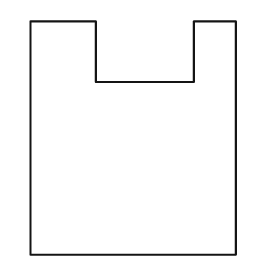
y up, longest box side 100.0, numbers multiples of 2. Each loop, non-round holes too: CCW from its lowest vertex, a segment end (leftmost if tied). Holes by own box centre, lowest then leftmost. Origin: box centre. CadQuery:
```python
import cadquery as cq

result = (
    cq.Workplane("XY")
    .moveTo(-44.0, -50.0)
    .lineTo(44.0, -50.0)
    .lineTo(44.0, 50.0)
    .lineTo(26.0, 50.0)
    .lineTo(26.0, 24.0)
    .lineTo(-16.0, 24.0)
    .lineTo(-16.0, 50.0)
    .lineTo(-44.0, 50.0)
    .close()
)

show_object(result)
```